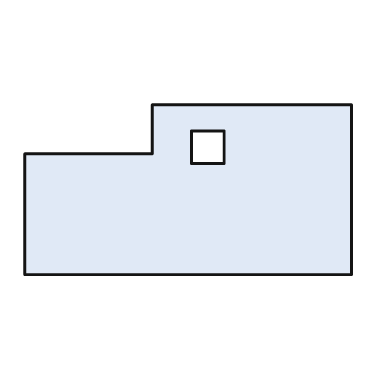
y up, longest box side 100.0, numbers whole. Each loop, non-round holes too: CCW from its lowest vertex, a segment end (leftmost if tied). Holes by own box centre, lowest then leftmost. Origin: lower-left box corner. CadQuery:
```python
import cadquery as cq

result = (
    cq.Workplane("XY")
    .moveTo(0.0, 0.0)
    .lineTo(100.0, 0.0)
    .lineTo(100.0, 52.0)
    .lineTo(39.0, 52.0)
    .lineTo(39.0, 37.0)
    .lineTo(0.0, 37.0)
    .close()
    .moveTo(51.0, 34.0)
    .lineTo(61.0, 34.0)
    .lineTo(61.0, 44.0)
    .lineTo(51.0, 44.0)
    .close()
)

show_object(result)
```